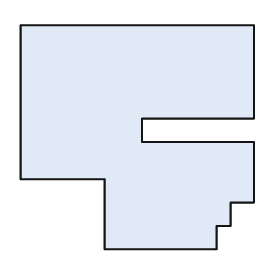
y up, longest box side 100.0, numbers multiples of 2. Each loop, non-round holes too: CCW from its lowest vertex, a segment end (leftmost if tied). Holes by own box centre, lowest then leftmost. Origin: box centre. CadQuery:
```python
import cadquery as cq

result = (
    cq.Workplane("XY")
    .moveTo(-14.0, -48.0)
    .lineTo(34.0, -48.0)
    .lineTo(34.0, -38.0)
    .lineTo(40.0, -38.0)
    .lineTo(40.0, -28.0)
    .lineTo(50.0, -28.0)
    .lineTo(50.0, -2.0)
    .lineTo(2.0, -2.0)
    .lineTo(2.0, 8.0)
    .lineTo(50.0, 8.0)
    .lineTo(50.0, 48.0)
    .lineTo(-50.0, 48.0)
    .lineTo(-50.0, -18.0)
    .lineTo(-14.0, -18.0)
    .close()
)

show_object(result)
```